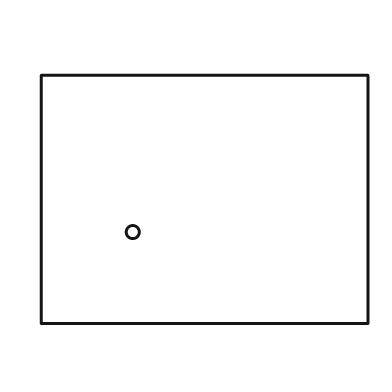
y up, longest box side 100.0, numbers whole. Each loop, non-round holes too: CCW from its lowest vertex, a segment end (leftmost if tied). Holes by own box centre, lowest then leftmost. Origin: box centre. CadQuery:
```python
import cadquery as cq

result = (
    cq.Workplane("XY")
    .moveTo(-50.0, -38.0)
    .lineTo(50.0, -38.0)
    .lineTo(50.0, 38.0)
    .lineTo(-50.0, 38.0)
    .close()
    .moveTo(-22.0, -10.0)
    .circle(2.0)
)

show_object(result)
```